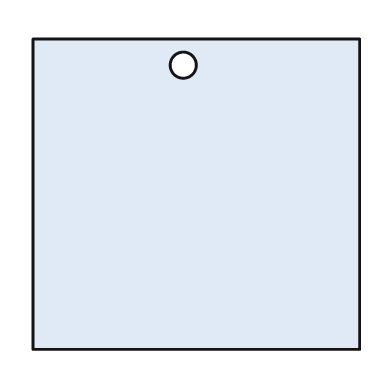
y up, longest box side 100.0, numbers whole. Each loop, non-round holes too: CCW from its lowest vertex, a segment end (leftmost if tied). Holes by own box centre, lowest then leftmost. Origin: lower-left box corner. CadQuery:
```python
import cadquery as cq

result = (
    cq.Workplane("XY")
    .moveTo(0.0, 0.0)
    .lineTo(100.0, 0.0)
    .lineTo(100.0, 95.0)
    .lineTo(0.0, 95.0)
    .close()
    .moveTo(46.0, 87.0)
    .circle(4.0)
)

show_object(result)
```